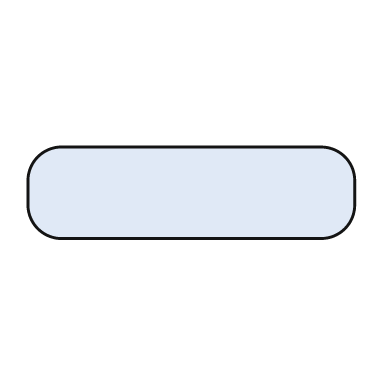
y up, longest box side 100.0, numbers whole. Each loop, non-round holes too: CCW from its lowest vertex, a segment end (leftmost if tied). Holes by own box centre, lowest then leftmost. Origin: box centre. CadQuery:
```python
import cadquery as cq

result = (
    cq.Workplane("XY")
    .moveTo(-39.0, -14.0)
    .lineTo(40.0, -14.0)
    .threePointArc((47.0, -11.0), (50.0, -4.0))
    .lineTo(50.0, 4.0)
    .threePointArc((47.0, 11.0), (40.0, 14.0))
    .lineTo(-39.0, 14.0)
    .threePointArc((-47.0, 11.0), (-50.0, 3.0))
    .lineTo(-50.0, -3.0)
    .threePointArc((-47.0, -11.0), (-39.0, -14.0))
    .close()
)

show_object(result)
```